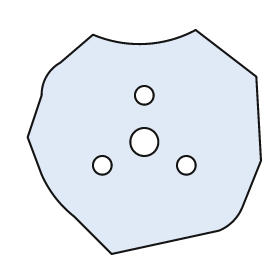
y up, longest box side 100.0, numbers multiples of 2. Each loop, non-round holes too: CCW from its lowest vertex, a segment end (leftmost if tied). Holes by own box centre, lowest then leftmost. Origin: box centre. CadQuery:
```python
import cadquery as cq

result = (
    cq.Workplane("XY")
    .moveTo(-14.0, -48.0)
    .lineTo(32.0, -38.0)
    .threePointArc((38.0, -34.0), (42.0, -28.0))
    .lineTo(50.0, -8.0)
    .lineTo(48.0, 28.0)
    .lineTo(22.0, 48.0)
    .threePointArc((0.0, 42.0), (-22.0, 46.0))
    .lineTo(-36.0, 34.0)
    .threePointArc((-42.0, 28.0), (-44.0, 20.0))
    .lineTo(-50.0, 2.0)
    .lineTo(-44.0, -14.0)
    .threePointArc((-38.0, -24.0), (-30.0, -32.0))
    .close()
    .moveTo(-18.0, -10.0)
    .circle(4.0)
    .moveTo(18.0, -10.0)
    .circle(4.0)
    .moveTo(0.0, 0.0)
    .circle(6.0)
    .moveTo(0.0, 20.0)
    .circle(4.0)
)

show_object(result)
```